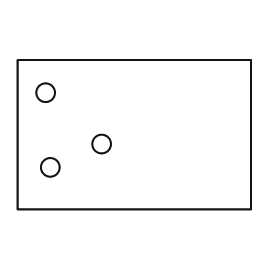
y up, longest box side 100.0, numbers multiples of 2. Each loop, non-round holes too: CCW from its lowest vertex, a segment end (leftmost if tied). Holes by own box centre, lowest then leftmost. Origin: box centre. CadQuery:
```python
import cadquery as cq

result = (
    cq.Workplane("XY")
    .moveTo(-50.0, -32.0)
    .lineTo(50.0, -32.0)
    .lineTo(50.0, 32.0)
    .lineTo(-50.0, 32.0)
    .close()
    .moveTo(-36.0, -14.0)
    .circle(4.0)
    .moveTo(-14.0, -4.0)
    .circle(4.0)
    .moveTo(-38.0, 18.0)
    .circle(4.0)
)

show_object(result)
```